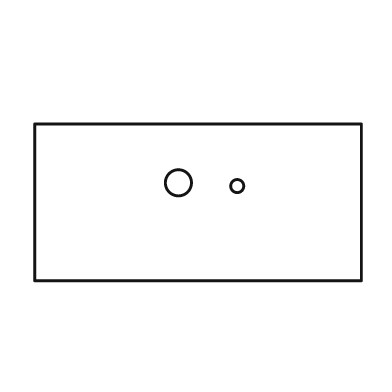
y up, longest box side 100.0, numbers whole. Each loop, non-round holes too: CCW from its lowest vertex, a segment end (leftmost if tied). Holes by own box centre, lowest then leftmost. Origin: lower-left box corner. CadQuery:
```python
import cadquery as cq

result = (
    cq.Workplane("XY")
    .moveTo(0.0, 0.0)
    .lineTo(100.0, 0.0)
    .lineTo(100.0, 48.0)
    .lineTo(0.0, 48.0)
    .close()
    .moveTo(62.0, 29.0)
    .circle(2.0)
    .moveTo(44.0, 30.0)
    .circle(4.0)
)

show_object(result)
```